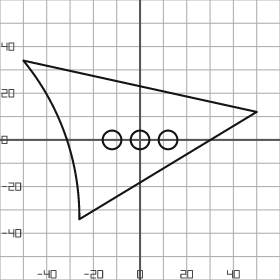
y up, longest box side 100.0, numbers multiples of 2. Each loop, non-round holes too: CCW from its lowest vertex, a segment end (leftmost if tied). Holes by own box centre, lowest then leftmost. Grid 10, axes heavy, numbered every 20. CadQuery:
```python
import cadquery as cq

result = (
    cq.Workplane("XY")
    .moveTo(-26.0, -34.0)
    .lineTo(50.0, 12.0)
    .lineTo(-50.0, 34.0)
    .threePointArc((-32.0, 2.0), (-26.0, -34.0))
    .close()
    .moveTo(-12.0, 0.0)
    .circle(4.0)
    .moveTo(0.0, 0.0)
    .circle(4.0)
    .moveTo(12.0, 0.0)
    .circle(4.0)
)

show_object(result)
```